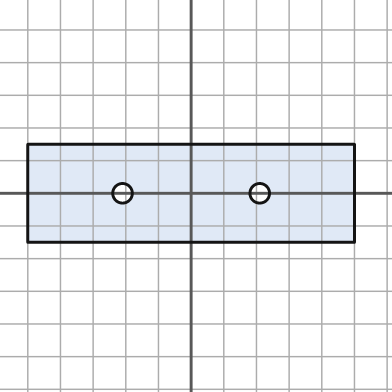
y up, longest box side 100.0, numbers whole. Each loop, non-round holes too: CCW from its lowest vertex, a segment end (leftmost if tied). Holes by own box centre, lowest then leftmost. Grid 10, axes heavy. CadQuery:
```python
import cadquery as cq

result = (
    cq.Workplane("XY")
    .moveTo(-50.0, -15.0)
    .lineTo(50.0, -15.0)
    .lineTo(50.0, 15.0)
    .lineTo(-50.0, 15.0)
    .close()
    .moveTo(-21.0, 0.0)
    .circle(3.0)
    .moveTo(21.0, 0.0)
    .circle(3.0)
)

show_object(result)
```